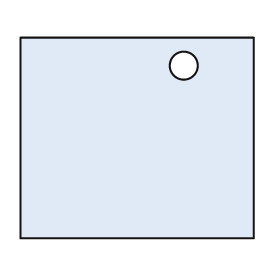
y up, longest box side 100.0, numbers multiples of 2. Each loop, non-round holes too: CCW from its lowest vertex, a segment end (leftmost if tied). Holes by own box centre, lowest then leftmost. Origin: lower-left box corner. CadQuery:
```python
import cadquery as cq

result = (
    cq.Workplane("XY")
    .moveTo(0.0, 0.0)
    .lineTo(100.0, 0.0)
    .lineTo(100.0, 86.0)
    .lineTo(0.0, 86.0)
    .close()
    .moveTo(70.0, 74.0)
    .circle(6.0)
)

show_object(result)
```